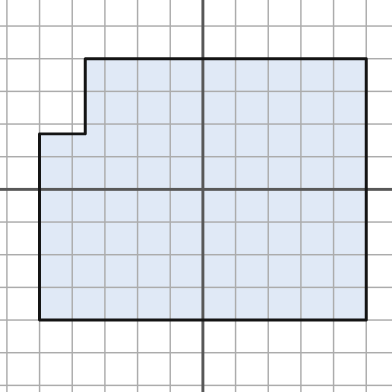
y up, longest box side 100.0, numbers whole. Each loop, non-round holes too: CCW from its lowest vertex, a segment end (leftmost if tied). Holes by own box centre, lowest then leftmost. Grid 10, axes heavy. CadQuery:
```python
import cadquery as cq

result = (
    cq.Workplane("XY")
    .moveTo(-50.0, -40.0)
    .lineTo(50.0, -40.0)
    .lineTo(50.0, 40.0)
    .lineTo(-36.0, 40.0)
    .lineTo(-36.0, 17.0)
    .lineTo(-50.0, 17.0)
    .close()
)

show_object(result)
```